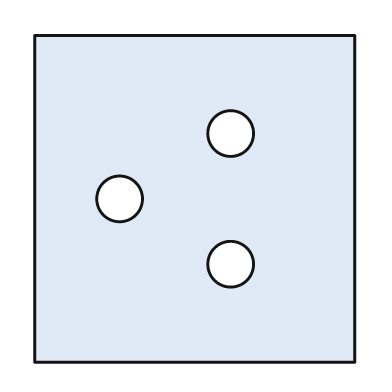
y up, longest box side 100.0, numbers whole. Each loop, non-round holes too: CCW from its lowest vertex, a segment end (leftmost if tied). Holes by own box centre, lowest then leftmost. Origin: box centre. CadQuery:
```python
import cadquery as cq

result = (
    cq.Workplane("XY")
    .moveTo(-49.0, -50.0)
    .lineTo(49.0, -50.0)
    .lineTo(49.0, 50.0)
    .lineTo(-49.0, 50.0)
    .close()
    .moveTo(11.0, -20.0)
    .circle(7.0)
    .moveTo(-23.0, 0.0)
    .circle(7.0)
    .moveTo(11.0, 20.0)
    .circle(7.0)
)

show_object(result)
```